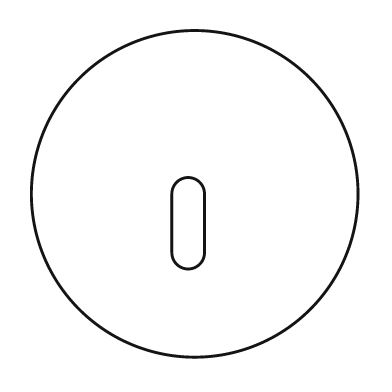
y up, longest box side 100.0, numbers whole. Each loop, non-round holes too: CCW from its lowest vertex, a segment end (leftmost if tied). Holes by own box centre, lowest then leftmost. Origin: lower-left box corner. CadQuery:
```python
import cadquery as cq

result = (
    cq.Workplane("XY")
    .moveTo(50.0, 50.0)
    .circle(50.0)
    .moveTo(43.0, 32.0)
    .threePointArc((48.0, 27.0), (53.0, 32.0))
    .lineTo(53.0, 50.0)
    .threePointArc((48.0, 55.0), (43.0, 50.0))
    .close()
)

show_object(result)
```